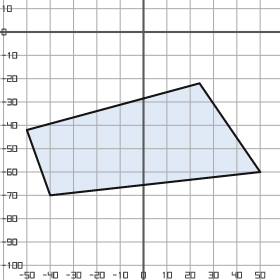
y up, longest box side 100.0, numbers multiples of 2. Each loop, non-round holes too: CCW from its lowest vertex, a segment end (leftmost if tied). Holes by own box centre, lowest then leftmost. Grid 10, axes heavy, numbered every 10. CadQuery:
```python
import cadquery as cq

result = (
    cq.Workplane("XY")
    .moveTo(-40.0, -70.0)
    .lineTo(50.0, -60.0)
    .lineTo(24.0, -22.0)
    .lineTo(-50.0, -42.0)
    .close()
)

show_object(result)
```